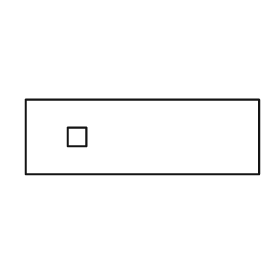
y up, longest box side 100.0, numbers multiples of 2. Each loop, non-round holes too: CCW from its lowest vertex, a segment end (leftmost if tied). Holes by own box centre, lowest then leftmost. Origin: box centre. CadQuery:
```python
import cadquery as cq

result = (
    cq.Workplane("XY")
    .moveTo(-50.0, -16.0)
    .lineTo(50.0, -16.0)
    .lineTo(50.0, 16.0)
    .lineTo(-50.0, 16.0)
    .close()
    .moveTo(-32.0, -4.0)
    .lineTo(-24.0, -4.0)
    .lineTo(-24.0, 4.0)
    .lineTo(-32.0, 4.0)
    .close()
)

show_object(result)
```